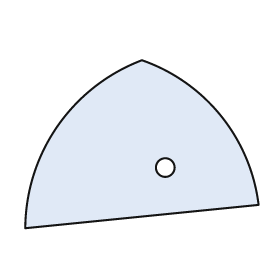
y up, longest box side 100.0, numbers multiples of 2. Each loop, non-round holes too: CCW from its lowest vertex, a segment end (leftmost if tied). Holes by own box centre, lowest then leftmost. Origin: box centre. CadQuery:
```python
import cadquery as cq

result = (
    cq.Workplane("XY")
    .moveTo(-50.0, -36.0)
    .lineTo(50.0, -26.0)
    .threePointArc((34.0, 12.0), (0.0, 36.0))
    .threePointArc((-36.0, 8.0), (-50.0, -36.0))
    .close()
    .moveTo(10.0, -10.0)
    .circle(4.0)
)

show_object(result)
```